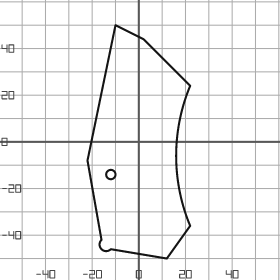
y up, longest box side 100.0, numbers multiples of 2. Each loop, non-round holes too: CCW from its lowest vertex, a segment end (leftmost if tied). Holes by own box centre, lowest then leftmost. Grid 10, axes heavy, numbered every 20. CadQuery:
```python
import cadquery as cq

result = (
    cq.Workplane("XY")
    .moveTo(12.0, -50.0)
    .lineTo(22.0, -36.0)
    .threePointArc((16.0, -6.0), (22.0, 24.0))
    .lineTo(2.0, 44.0)
    .lineTo(-10.0, 50.0)
    .lineTo(-22.0, -8.0)
    .lineTo(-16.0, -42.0)
    .threePointArc((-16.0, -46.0), (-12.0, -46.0))
    .close()
    .moveTo(-12.0, -14.0)
    .circle(2.0)
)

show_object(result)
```